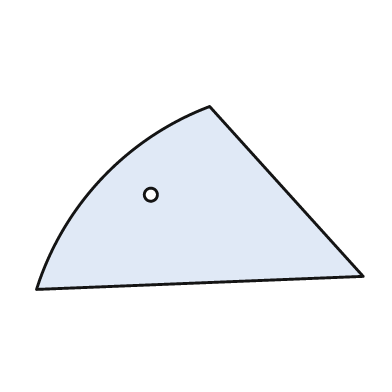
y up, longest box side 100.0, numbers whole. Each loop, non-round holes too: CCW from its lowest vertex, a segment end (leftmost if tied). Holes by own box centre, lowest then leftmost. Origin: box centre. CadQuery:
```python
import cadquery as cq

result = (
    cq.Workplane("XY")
    .moveTo(-50.0, -28.0)
    .lineTo(50.0, -24.0)
    .lineTo(3.0, 28.0)
    .threePointArc((-30.0, 6.0), (-50.0, -28.0))
    .close()
    .moveTo(-15.0, 1.0)
    .circle(2.0)
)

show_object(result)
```